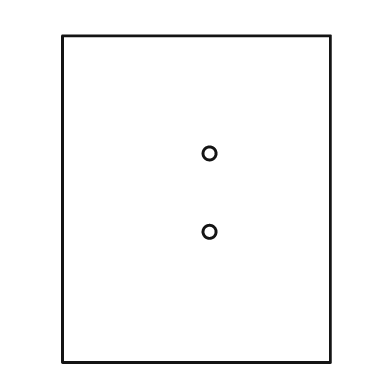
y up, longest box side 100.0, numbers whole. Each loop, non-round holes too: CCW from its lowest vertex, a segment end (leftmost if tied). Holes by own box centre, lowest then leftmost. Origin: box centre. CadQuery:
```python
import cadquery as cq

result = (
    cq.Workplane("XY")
    .moveTo(-41.0, -50.0)
    .lineTo(41.0, -50.0)
    .lineTo(41.0, 50.0)
    .lineTo(-41.0, 50.0)
    .close()
    .moveTo(4.0, -10.0)
    .circle(2.0)
    .moveTo(4.0, 14.0)
    .circle(2.0)
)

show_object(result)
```